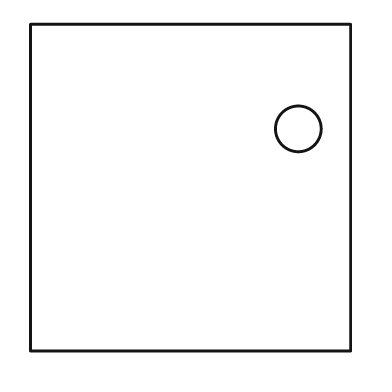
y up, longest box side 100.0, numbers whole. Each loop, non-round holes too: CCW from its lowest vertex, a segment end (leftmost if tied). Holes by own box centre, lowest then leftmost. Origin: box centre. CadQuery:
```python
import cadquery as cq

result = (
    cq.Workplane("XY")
    .moveTo(-49.0, -50.0)
    .lineTo(49.0, -50.0)
    .lineTo(49.0, 50.0)
    .lineTo(-49.0, 50.0)
    .close()
    .moveTo(33.0, 18.0)
    .circle(7.0)
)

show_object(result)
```